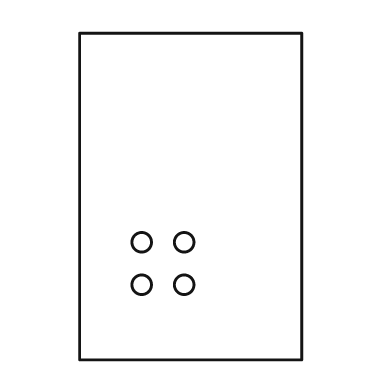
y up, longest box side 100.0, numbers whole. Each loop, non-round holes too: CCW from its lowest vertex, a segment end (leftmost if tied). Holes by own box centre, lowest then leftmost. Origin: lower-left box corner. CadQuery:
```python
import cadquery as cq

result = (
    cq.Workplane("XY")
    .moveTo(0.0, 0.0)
    .lineTo(68.0, 0.0)
    .lineTo(68.0, 100.0)
    .lineTo(0.0, 100.0)
    .close()
    .moveTo(19.0, 23.0)
    .circle(3.0)
    .moveTo(32.0, 23.0)
    .circle(3.0)
    .moveTo(19.0, 36.0)
    .circle(3.0)
    .moveTo(32.0, 36.0)
    .circle(3.0)
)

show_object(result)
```